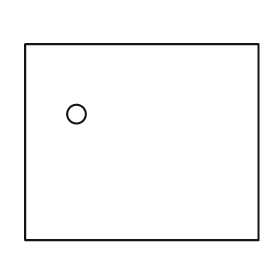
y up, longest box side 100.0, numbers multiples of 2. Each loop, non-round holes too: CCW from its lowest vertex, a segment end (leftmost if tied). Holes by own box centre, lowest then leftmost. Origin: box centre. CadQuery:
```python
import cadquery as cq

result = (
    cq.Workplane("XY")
    .moveTo(-50.0, -42.0)
    .lineTo(50.0, -42.0)
    .lineTo(50.0, 42.0)
    .lineTo(-50.0, 42.0)
    .close()
    .moveTo(-28.0, 12.0)
    .circle(4.0)
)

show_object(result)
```